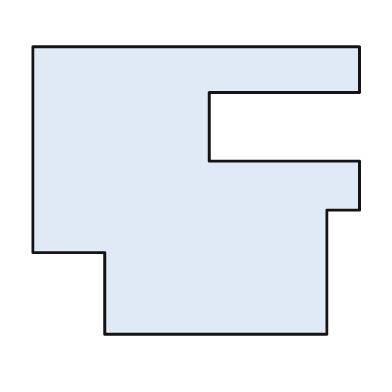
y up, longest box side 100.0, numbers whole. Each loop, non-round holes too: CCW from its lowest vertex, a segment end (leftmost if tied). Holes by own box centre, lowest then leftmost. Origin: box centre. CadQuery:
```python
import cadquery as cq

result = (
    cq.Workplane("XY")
    .moveTo(-28.0, -44.0)
    .lineTo(40.0, -44.0)
    .lineTo(40.0, -6.0)
    .lineTo(50.0, -6.0)
    .lineTo(50.0, 9.0)
    .lineTo(4.0, 9.0)
    .lineTo(4.0, 30.0)
    .lineTo(50.0, 30.0)
    .lineTo(50.0, 44.0)
    .lineTo(-50.0, 44.0)
    .lineTo(-50.0, -19.0)
    .lineTo(-28.0, -19.0)
    .close()
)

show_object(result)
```